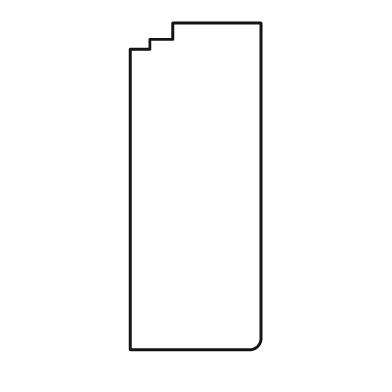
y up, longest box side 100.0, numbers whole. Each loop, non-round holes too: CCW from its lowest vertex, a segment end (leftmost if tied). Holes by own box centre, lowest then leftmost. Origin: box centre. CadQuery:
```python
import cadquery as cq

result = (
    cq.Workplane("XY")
    .moveTo(-20.0, -50.0)
    .lineTo(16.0, -50.0)
    .threePointArc((19.0, -49.0), (20.0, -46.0))
    .lineTo(20.0, 50.0)
    .lineTo(-7.0, 50.0)
    .lineTo(-7.0, 45.0)
    .lineTo(-14.0, 45.0)
    .lineTo(-14.0, 42.0)
    .lineTo(-20.0, 42.0)
    .close()
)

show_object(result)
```